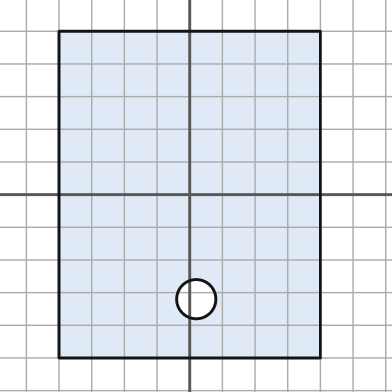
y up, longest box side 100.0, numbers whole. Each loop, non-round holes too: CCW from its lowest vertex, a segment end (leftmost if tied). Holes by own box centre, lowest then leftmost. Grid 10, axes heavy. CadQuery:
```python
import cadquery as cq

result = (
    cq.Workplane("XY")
    .moveTo(-40.0, -50.0)
    .lineTo(40.0, -50.0)
    .lineTo(40.0, 50.0)
    .lineTo(-40.0, 50.0)
    .close()
    .moveTo(2.0, -32.0)
    .circle(6.0)
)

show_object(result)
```